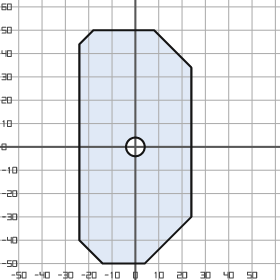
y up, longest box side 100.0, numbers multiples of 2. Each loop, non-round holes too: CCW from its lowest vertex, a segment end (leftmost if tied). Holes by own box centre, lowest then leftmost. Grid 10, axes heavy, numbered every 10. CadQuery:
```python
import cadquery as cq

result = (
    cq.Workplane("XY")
    .moveTo(-14.0, -50.0)
    .lineTo(4.0, -50.0)
    .lineTo(24.0, -30.0)
    .lineTo(24.0, 34.0)
    .lineTo(8.0, 50.0)
    .lineTo(-18.0, 50.0)
    .lineTo(-24.0, 44.0)
    .lineTo(-24.0, -40.0)
    .close()
    .moveTo(0.0, 0.0)
    .circle(4.0)
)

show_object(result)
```